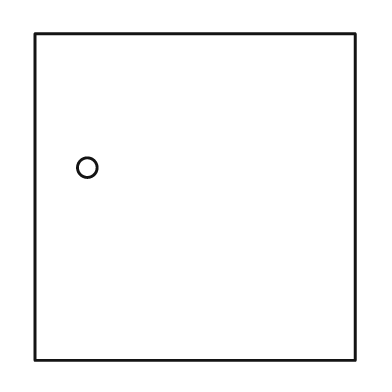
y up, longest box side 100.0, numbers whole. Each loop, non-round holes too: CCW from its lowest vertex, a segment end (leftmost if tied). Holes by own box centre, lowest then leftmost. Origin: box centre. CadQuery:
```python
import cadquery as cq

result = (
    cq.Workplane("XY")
    .moveTo(-49.0, -50.0)
    .lineTo(49.0, -50.0)
    .lineTo(49.0, 50.0)
    .lineTo(-49.0, 50.0)
    .close()
    .moveTo(-33.0, 9.0)
    .circle(3.0)
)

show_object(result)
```